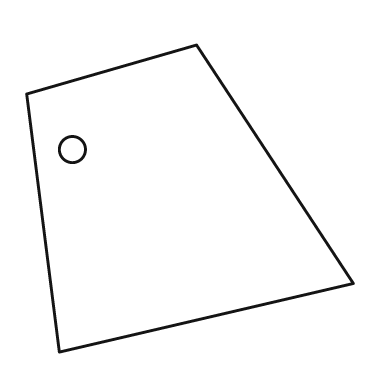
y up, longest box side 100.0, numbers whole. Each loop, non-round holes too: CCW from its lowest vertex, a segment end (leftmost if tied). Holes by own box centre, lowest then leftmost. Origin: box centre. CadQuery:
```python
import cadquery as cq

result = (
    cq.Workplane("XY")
    .moveTo(-40.0, -47.0)
    .lineTo(50.0, -26.0)
    .lineTo(2.0, 47.0)
    .lineTo(-50.0, 32.0)
    .close()
    .moveTo(-36.0, 15.0)
    .circle(4.0)
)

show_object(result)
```